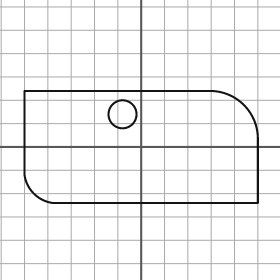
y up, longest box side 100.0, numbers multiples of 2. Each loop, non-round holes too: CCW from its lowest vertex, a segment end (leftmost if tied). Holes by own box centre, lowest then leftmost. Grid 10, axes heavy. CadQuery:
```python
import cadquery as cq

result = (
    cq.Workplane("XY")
    .moveTo(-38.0, -24.0)
    .lineTo(50.0, -24.0)
    .lineTo(50.0, 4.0)
    .threePointArc((44.0, 18.0), (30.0, 24.0))
    .lineTo(-50.0, 24.0)
    .lineTo(-50.0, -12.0)
    .threePointArc((-46.0, -20.0), (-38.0, -24.0))
    .close()
    .moveTo(-8.0, 14.0)
    .circle(6.0)
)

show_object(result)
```